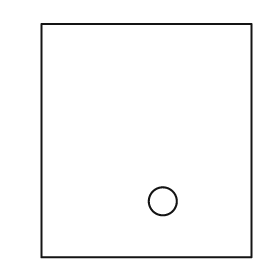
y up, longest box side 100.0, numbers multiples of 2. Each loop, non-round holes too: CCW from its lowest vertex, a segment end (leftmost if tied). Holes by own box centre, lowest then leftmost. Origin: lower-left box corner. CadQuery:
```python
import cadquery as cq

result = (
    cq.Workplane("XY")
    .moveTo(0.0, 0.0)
    .lineTo(90.0, 0.0)
    .lineTo(90.0, 100.0)
    .lineTo(0.0, 100.0)
    .close()
    .moveTo(52.0, 24.0)
    .circle(6.0)
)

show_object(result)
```